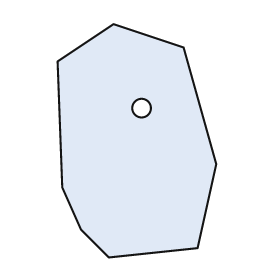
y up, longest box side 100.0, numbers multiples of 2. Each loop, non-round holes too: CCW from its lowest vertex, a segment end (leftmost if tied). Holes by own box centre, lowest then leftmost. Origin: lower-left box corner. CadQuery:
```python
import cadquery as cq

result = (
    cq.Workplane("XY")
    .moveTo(22.0, 0.0)
    .lineTo(60.0, 4.0)
    .lineTo(68.0, 40.0)
    .lineTo(54.0, 90.0)
    .lineTo(24.0, 100.0)
    .lineTo(0.0, 84.0)
    .lineTo(2.0, 30.0)
    .lineTo(10.0, 12.0)
    .close()
    .moveTo(36.0, 64.0)
    .circle(4.0)
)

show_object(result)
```